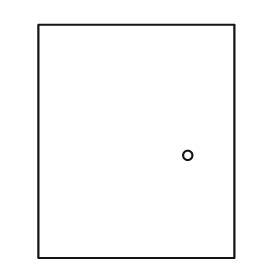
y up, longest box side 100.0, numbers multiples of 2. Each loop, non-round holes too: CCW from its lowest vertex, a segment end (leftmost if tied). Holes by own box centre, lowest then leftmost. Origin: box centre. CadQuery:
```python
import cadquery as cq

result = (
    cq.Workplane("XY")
    .moveTo(-42.0, -50.0)
    .lineTo(42.0, -50.0)
    .lineTo(42.0, 50.0)
    .lineTo(-42.0, 50.0)
    .close()
    .moveTo(22.0, -6.0)
    .circle(2.0)
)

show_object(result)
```